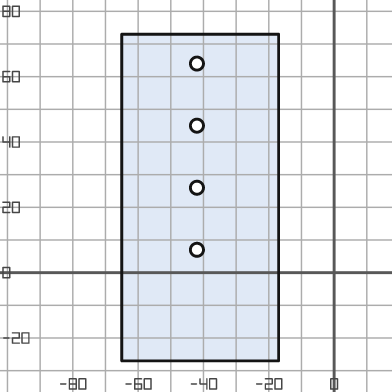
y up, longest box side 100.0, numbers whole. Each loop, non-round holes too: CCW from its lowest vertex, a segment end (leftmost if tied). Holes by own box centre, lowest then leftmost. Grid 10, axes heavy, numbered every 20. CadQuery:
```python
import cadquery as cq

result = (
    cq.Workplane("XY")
    .moveTo(-65.0, -27.0)
    .lineTo(-17.0, -27.0)
    .lineTo(-17.0, 73.0)
    .lineTo(-65.0, 73.0)
    .close()
    .moveTo(-42.0, 7.0)
    .circle(2.0)
    .moveTo(-42.0, 26.0)
    .circle(2.0)
    .moveTo(-42.0, 45.0)
    .circle(2.0)
    .moveTo(-42.0, 64.0)
    .circle(2.0)
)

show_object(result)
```